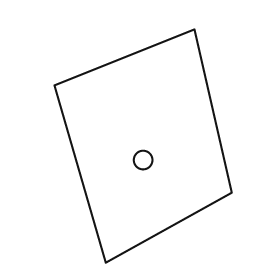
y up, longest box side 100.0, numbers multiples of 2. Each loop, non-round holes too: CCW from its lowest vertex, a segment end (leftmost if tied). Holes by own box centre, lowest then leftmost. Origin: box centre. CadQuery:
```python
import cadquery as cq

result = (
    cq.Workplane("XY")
    .moveTo(-16.0, -50.0)
    .lineTo(38.0, -20.0)
    .lineTo(22.0, 50.0)
    .lineTo(-38.0, 26.0)
    .close()
    .moveTo(0.0, -6.0)
    .circle(4.0)
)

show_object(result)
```